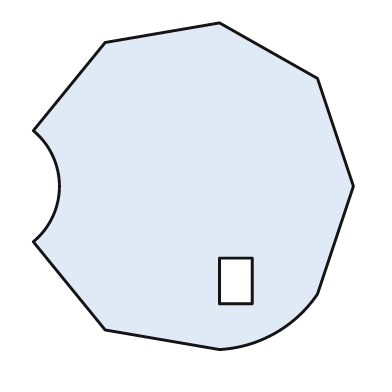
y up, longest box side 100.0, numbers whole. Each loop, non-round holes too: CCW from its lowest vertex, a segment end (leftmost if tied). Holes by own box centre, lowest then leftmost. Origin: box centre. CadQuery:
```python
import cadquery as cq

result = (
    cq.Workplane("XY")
    .moveTo(8.0, -50.0)
    .threePointArc((25.0, -45.0), (38.0, -33.0))
    .lineTo(49.0, 0.0)
    .lineTo(38.0, 33.0)
    .lineTo(8.0, 50.0)
    .lineTo(-27.0, 44.0)
    .lineTo(-49.0, 17.0)
    .threePointArc((-41.0, 0.0), (-49.0, -17.0))
    .lineTo(-27.0, -44.0)
    .close()
    .moveTo(8.0, -36.0)
    .lineTo(18.0, -36.0)
    .lineTo(18.0, -22.0)
    .lineTo(8.0, -22.0)
    .close()
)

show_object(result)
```